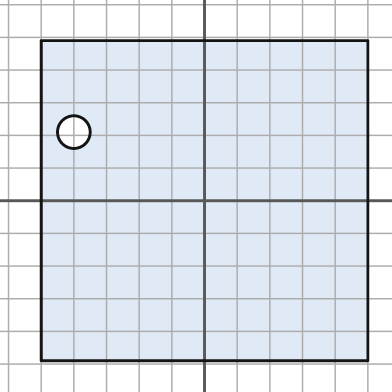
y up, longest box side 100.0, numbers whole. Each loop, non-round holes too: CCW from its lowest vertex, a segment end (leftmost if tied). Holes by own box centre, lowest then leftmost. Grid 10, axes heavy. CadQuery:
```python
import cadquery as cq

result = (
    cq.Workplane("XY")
    .moveTo(-50.0, -49.0)
    .lineTo(50.0, -49.0)
    .lineTo(50.0, 49.0)
    .lineTo(-50.0, 49.0)
    .close()
    .moveTo(-40.0, 21.0)
    .circle(5.0)
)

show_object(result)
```